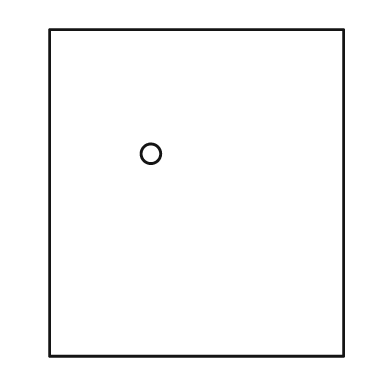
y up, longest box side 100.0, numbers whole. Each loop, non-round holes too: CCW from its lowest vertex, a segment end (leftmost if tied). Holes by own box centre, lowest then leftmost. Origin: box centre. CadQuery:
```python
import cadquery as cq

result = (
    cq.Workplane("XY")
    .moveTo(-45.0, -50.0)
    .lineTo(45.0, -50.0)
    .lineTo(45.0, 50.0)
    .lineTo(-45.0, 50.0)
    .close()
    .moveTo(-14.0, 12.0)
    .circle(3.0)
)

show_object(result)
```